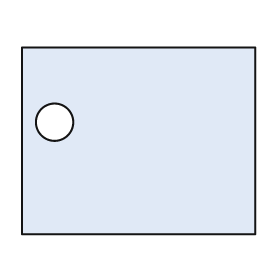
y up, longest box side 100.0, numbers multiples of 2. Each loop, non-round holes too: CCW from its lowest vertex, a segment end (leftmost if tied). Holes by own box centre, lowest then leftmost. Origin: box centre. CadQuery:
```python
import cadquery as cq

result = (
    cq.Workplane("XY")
    .moveTo(-50.0, -40.0)
    .lineTo(50.0, -40.0)
    .lineTo(50.0, 40.0)
    .lineTo(-50.0, 40.0)
    .close()
    .moveTo(-36.0, 8.0)
    .circle(8.0)
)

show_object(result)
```